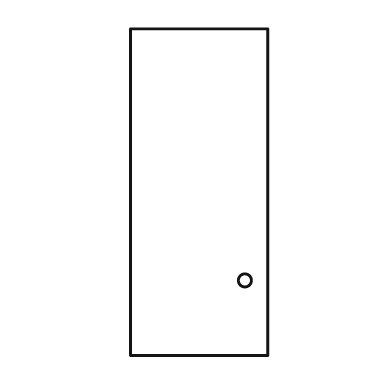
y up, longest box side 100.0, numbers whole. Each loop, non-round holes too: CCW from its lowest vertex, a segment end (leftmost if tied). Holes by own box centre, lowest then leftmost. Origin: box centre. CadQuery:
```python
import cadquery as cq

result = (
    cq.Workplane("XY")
    .moveTo(-21.0, -50.0)
    .lineTo(21.0, -50.0)
    .lineTo(21.0, 50.0)
    .lineTo(-21.0, 50.0)
    .close()
    .moveTo(14.0, -27.0)
    .circle(2.0)
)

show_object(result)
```